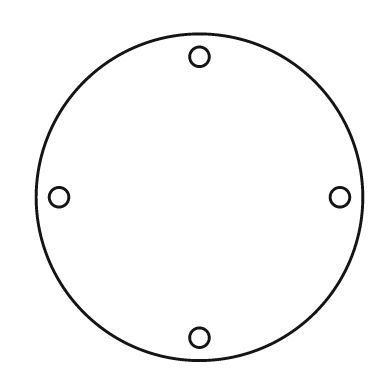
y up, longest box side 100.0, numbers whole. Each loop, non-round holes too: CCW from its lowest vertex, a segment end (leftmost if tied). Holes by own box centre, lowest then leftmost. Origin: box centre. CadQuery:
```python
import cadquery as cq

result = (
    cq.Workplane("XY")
    .moveTo(0.0, 0.0)
    .circle(50.0)
    .moveTo(0.0, -43.0)
    .circle(3.0)
    .moveTo(-43.0, 0.0)
    .circle(3.0)
    .moveTo(43.0, 0.0)
    .circle(3.0)
    .moveTo(0.0, 43.0)
    .circle(3.0)
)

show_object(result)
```